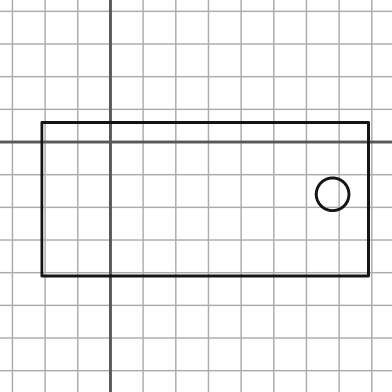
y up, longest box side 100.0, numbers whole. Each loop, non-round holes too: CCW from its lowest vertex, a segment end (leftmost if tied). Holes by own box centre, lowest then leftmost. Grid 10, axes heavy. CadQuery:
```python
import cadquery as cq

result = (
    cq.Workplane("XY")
    .moveTo(-21.0, -41.0)
    .lineTo(79.0, -41.0)
    .lineTo(79.0, 6.0)
    .lineTo(-21.0, 6.0)
    .close()
    .moveTo(68.0, -16.0)
    .circle(5.0)
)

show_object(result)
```